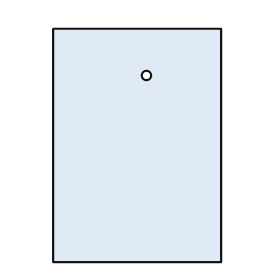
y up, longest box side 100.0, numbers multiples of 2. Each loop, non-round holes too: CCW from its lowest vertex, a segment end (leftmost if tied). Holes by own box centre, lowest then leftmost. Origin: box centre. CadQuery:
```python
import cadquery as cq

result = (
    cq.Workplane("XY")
    .moveTo(-36.0, -50.0)
    .lineTo(36.0, -50.0)
    .lineTo(36.0, 50.0)
    .lineTo(-36.0, 50.0)
    .close()
    .moveTo(4.0, 30.0)
    .circle(2.0)
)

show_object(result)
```